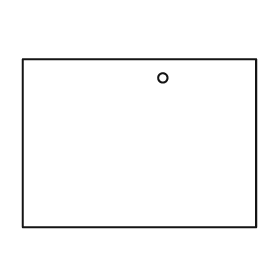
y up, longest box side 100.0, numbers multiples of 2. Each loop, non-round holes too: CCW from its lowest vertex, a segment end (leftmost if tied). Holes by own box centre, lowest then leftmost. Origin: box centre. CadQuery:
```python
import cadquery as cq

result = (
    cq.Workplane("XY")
    .moveTo(-50.0, -36.0)
    .lineTo(50.0, -36.0)
    .lineTo(50.0, 36.0)
    .lineTo(-50.0, 36.0)
    .close()
    .moveTo(10.0, 28.0)
    .circle(2.0)
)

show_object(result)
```